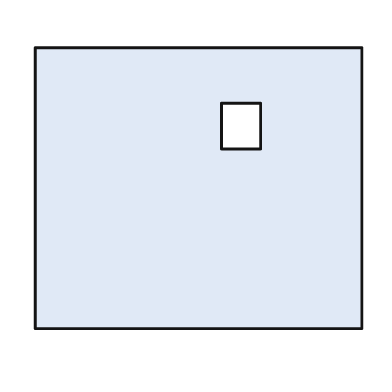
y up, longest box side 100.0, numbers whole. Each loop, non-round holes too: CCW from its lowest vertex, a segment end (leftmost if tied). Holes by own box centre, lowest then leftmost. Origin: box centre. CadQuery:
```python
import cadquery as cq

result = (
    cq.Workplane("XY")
    .moveTo(-50.0, -43.0)
    .lineTo(50.0, -43.0)
    .lineTo(50.0, 43.0)
    .lineTo(-50.0, 43.0)
    .close()
    .moveTo(7.0, 12.0)
    .lineTo(19.0, 12.0)
    .lineTo(19.0, 26.0)
    .lineTo(7.0, 26.0)
    .close()
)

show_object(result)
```